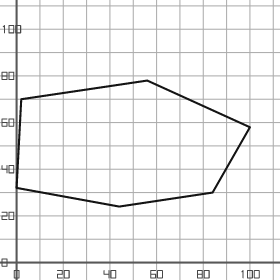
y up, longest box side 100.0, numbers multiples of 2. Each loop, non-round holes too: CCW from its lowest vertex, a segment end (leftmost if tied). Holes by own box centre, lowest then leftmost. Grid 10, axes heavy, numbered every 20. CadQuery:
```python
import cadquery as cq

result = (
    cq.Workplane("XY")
    .moveTo(44.0, 24.0)
    .lineTo(84.0, 30.0)
    .lineTo(100.0, 58.0)
    .lineTo(56.0, 78.0)
    .lineTo(2.0, 70.0)
    .lineTo(0.0, 32.0)
    .close()
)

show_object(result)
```